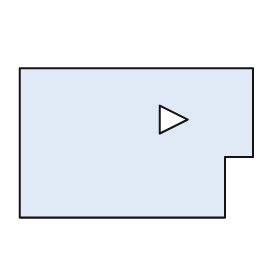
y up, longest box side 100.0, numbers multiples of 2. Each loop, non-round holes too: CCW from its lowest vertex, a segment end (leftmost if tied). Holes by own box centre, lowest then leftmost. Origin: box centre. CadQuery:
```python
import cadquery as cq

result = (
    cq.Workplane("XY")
    .moveTo(-50.0, -32.0)
    .lineTo(38.0, -32.0)
    .lineTo(38.0, -6.0)
    .lineTo(50.0, -6.0)
    .lineTo(50.0, 32.0)
    .lineTo(-50.0, 32.0)
    .close()
    .moveTo(10.0, 4.0)
    .lineTo(22.0, 10.0)
    .lineTo(10.0, 16.0)
    .close()
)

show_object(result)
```